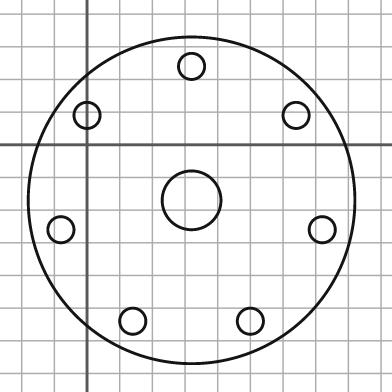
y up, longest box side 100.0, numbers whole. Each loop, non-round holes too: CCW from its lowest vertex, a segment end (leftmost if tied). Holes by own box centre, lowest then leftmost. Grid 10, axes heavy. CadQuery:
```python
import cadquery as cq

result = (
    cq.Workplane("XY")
    .moveTo(32.0, -17.0)
    .circle(50.0)
    .moveTo(14.0, -54.0)
    .circle(4.0)
    .moveTo(50.0, -54.0)
    .circle(4.0)
    .moveTo(-8.0, -26.0)
    .circle(4.0)
    .moveTo(72.0, -26.0)
    .circle(4.0)
    .moveTo(32.0, -17.0)
    .circle(9.0)
    .moveTo(0.0, 9.0)
    .circle(4.0)
    .moveTo(64.0, 9.0)
    .circle(4.0)
    .moveTo(32.0, 24.0)
    .circle(4.0)
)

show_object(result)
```